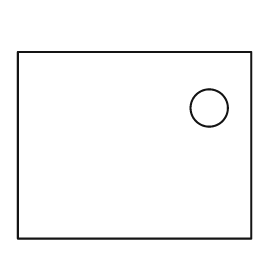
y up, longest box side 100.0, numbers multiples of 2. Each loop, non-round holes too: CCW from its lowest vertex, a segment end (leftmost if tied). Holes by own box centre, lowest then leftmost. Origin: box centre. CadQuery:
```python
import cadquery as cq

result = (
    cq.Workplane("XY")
    .moveTo(-50.0, -40.0)
    .lineTo(50.0, -40.0)
    .lineTo(50.0, 40.0)
    .lineTo(-50.0, 40.0)
    .close()
    .moveTo(32.0, 16.0)
    .circle(8.0)
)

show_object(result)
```